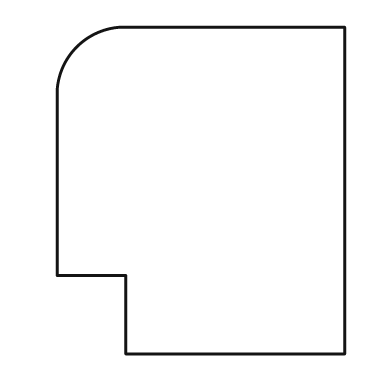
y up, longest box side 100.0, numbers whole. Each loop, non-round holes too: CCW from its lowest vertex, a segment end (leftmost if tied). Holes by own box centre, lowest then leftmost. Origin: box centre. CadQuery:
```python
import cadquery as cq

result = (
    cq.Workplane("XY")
    .moveTo(-23.0, -50.0)
    .lineTo(44.0, -50.0)
    .lineTo(44.0, 50.0)
    .lineTo(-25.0, 50.0)
    .threePointArc((-38.0, 44.0), (-44.0, 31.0))
    .lineTo(-44.0, -26.0)
    .lineTo(-23.0, -26.0)
    .close()
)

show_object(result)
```